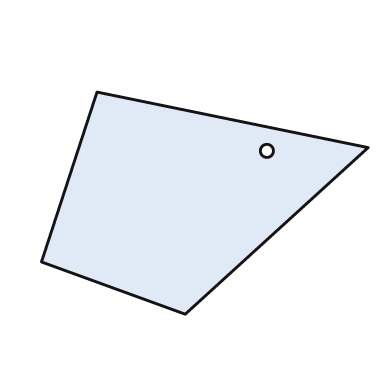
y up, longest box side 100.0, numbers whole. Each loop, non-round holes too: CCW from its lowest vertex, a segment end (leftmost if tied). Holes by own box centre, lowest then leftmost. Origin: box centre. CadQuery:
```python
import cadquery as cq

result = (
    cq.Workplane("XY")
    .moveTo(-6.0, -34.0)
    .lineTo(50.0, 17.0)
    .lineTo(-33.0, 34.0)
    .lineTo(-50.0, -18.0)
    .close()
    .moveTo(19.0, 16.0)
    .circle(2.0)
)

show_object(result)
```